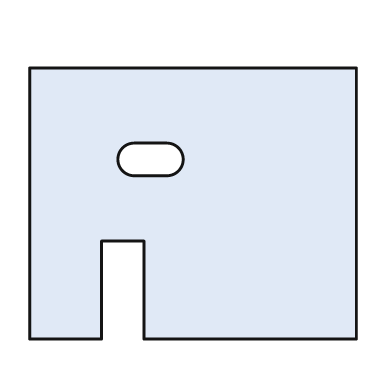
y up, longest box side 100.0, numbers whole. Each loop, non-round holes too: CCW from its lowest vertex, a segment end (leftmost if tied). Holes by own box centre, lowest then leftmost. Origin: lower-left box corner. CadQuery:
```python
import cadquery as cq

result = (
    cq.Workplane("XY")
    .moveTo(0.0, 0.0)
    .lineTo(22.0, 0.0)
    .lineTo(22.0, 30.0)
    .lineTo(35.0, 30.0)
    .lineTo(35.0, 0.0)
    .lineTo(100.0, 0.0)
    .lineTo(100.0, 83.0)
    .lineTo(0.0, 83.0)
    .close()
    .moveTo(32.0, 50.0)
    .lineTo(42.0, 50.0)
    .threePointArc((47.0, 55.0), (42.0, 60.0))
    .lineTo(32.0, 60.0)
    .threePointArc((27.0, 55.0), (32.0, 50.0))
    .close()
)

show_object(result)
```